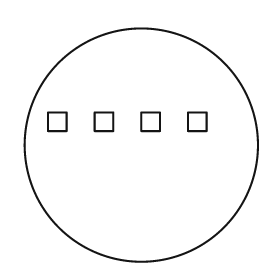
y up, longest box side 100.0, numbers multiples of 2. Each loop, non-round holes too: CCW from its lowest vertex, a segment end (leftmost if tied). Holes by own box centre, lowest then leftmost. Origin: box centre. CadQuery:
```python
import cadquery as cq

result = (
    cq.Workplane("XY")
    .moveTo(0.0, 0.0)
    .circle(50.0)
    .moveTo(-40.0, 6.0)
    .lineTo(-32.0, 6.0)
    .lineTo(-32.0, 14.0)
    .lineTo(-40.0, 14.0)
    .close()
    .moveTo(-20.0, 6.0)
    .lineTo(-12.0, 6.0)
    .lineTo(-12.0, 14.0)
    .lineTo(-20.0, 14.0)
    .close()
    .moveTo(0.0, 6.0)
    .lineTo(8.0, 6.0)
    .lineTo(8.0, 14.0)
    .lineTo(0.0, 14.0)
    .close()
    .moveTo(20.0, 6.0)
    .lineTo(28.0, 6.0)
    .lineTo(28.0, 14.0)
    .lineTo(20.0, 14.0)
    .close()
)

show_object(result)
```